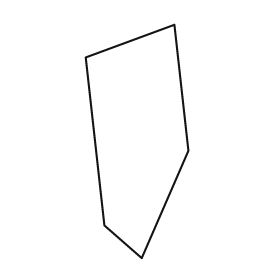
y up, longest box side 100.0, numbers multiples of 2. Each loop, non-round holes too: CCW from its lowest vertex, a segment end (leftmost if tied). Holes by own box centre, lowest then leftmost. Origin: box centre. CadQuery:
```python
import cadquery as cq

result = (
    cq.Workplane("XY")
    .moveTo(2.0, -50.0)
    .lineTo(22.0, -4.0)
    .lineTo(16.0, 50.0)
    .lineTo(-22.0, 36.0)
    .lineTo(-14.0, -36.0)
    .close()
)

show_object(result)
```